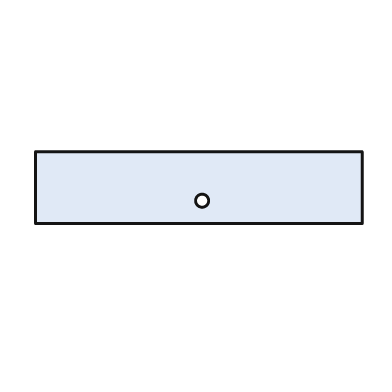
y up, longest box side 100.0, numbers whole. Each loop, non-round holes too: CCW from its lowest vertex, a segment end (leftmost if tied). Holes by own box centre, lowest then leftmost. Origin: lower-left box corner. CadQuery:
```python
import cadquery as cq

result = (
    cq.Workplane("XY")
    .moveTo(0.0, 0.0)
    .lineTo(100.0, 0.0)
    .lineTo(100.0, 22.0)
    .lineTo(0.0, 22.0)
    .close()
    .moveTo(51.0, 7.0)
    .circle(2.0)
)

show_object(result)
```